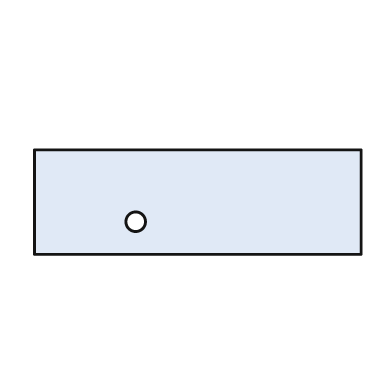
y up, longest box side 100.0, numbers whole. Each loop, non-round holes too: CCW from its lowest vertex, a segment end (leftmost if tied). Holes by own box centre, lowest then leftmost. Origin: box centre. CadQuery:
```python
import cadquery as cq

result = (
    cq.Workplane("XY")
    .moveTo(-50.0, -16.0)
    .lineTo(50.0, -16.0)
    .lineTo(50.0, 16.0)
    .lineTo(-50.0, 16.0)
    .close()
    .moveTo(-19.0, -6.0)
    .circle(3.0)
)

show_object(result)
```